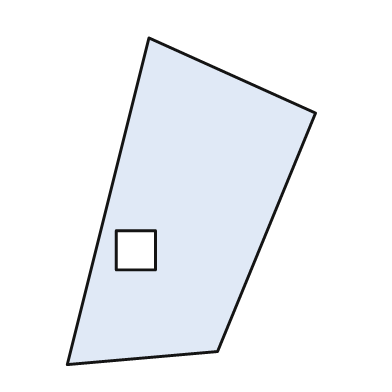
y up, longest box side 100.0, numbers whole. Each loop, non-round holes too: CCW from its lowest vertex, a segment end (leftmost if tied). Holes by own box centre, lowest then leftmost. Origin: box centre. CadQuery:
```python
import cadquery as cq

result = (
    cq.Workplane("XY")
    .moveTo(-38.0, -50.0)
    .lineTo(8.0, -46.0)
    .lineTo(38.0, 27.0)
    .lineTo(-13.0, 50.0)
    .close()
    .moveTo(-23.0, -21.0)
    .lineTo(-11.0, -21.0)
    .lineTo(-11.0, -9.0)
    .lineTo(-23.0, -9.0)
    .close()
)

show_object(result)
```